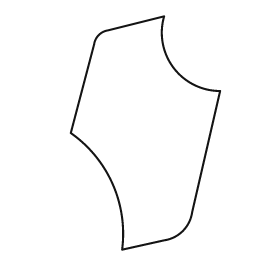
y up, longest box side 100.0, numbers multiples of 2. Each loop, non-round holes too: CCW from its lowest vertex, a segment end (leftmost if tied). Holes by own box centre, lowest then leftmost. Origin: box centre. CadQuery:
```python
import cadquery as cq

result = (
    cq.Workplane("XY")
    .moveTo(-10.0, -50.0)
    .lineTo(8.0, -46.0)
    .threePointArc((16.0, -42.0), (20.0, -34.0))
    .lineTo(32.0, 18.0)
    .threePointArc((12.0, 28.0), (8.0, 50.0))
    .lineTo(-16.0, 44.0)
    .threePointArc((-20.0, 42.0), (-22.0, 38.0))
    .lineTo(-32.0, 0.0)
    .threePointArc((-14.0, -22.0), (-10.0, -50.0))
    .close()
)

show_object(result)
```